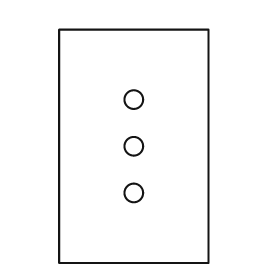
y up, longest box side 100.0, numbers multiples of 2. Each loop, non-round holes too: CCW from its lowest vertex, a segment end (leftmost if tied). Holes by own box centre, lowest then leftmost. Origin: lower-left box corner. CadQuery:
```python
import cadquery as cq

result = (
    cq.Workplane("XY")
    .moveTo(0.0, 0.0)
    .lineTo(64.0, 0.0)
    .lineTo(64.0, 100.0)
    .lineTo(0.0, 100.0)
    .close()
    .moveTo(32.0, 30.0)
    .circle(4.0)
    .moveTo(32.0, 50.0)
    .circle(4.0)
    .moveTo(32.0, 70.0)
    .circle(4.0)
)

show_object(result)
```